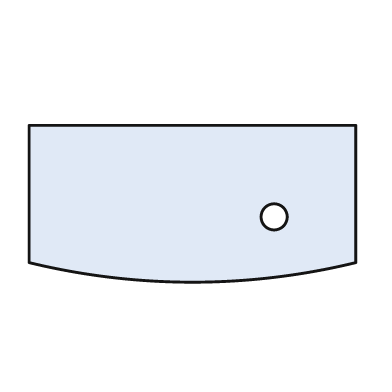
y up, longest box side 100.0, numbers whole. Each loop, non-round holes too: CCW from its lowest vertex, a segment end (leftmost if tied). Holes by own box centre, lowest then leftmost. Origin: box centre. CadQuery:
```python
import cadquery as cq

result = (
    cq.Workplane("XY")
    .moveTo(-50.0, -18.0)
    .threePointArc((0.0, -24.0), (50.0, -18.0))
    .lineTo(50.0, 24.0)
    .lineTo(-50.0, 24.0)
    .close()
    .moveTo(25.0, -4.0)
    .circle(4.0)
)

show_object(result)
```